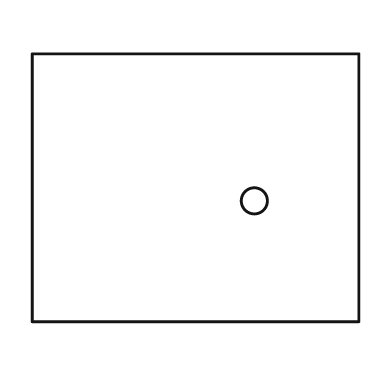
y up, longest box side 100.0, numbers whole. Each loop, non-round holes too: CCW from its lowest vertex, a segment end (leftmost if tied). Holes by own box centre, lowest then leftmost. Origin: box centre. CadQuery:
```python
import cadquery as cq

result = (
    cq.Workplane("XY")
    .moveTo(-50.0, -41.0)
    .lineTo(50.0, -41.0)
    .lineTo(50.0, 41.0)
    .lineTo(-50.0, 41.0)
    .close()
    .moveTo(18.0, -4.0)
    .circle(4.0)
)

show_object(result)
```